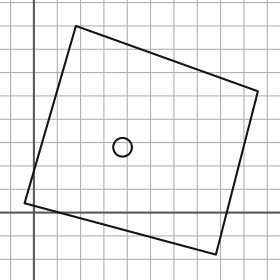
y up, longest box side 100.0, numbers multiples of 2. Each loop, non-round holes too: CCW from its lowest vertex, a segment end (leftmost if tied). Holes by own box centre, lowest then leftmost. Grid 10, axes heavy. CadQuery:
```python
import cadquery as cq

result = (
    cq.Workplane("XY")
    .moveTo(78.0, -18.0)
    .lineTo(96.0, 52.0)
    .lineTo(18.0, 80.0)
    .lineTo(-4.0, 4.0)
    .close()
    .moveTo(38.0, 28.0)
    .circle(4.0)
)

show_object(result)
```